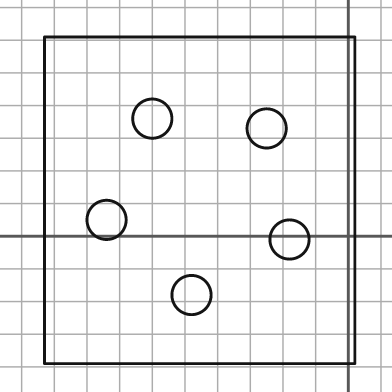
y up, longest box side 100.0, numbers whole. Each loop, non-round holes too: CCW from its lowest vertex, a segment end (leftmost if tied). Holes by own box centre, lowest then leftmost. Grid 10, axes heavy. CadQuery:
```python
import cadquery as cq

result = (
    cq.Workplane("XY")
    .moveTo(-93.0, -39.0)
    .lineTo(2.0, -39.0)
    .lineTo(2.0, 61.0)
    .lineTo(-93.0, 61.0)
    .close()
    .moveTo(-48.0, -18.0)
    .circle(6.0)
    .moveTo(-18.0, -1.0)
    .circle(6.0)
    .moveTo(-74.0, 5.0)
    .circle(6.0)
    .moveTo(-25.0, 33.0)
    .circle(6.0)
    .moveTo(-60.0, 36.0)
    .circle(6.0)
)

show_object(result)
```